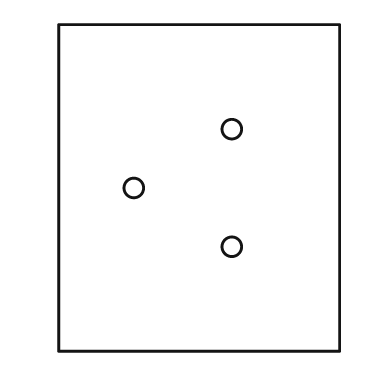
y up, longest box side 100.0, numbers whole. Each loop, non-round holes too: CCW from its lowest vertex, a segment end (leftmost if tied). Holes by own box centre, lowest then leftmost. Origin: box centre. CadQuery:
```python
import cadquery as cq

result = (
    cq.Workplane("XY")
    .moveTo(-43.0, -50.0)
    .lineTo(43.0, -50.0)
    .lineTo(43.0, 50.0)
    .lineTo(-43.0, 50.0)
    .close()
    .moveTo(10.0, -18.0)
    .circle(3.0)
    .moveTo(-20.0, 0.0)
    .circle(3.0)
    .moveTo(10.0, 18.0)
    .circle(3.0)
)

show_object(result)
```